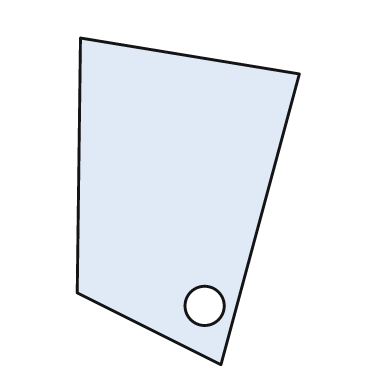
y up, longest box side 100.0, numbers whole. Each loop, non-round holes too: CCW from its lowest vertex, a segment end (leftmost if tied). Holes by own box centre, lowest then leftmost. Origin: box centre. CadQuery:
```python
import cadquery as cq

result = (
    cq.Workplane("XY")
    .moveTo(10.0, -50.0)
    .lineTo(34.0, 39.0)
    .lineTo(-33.0, 50.0)
    .lineTo(-34.0, -28.0)
    .close()
    .moveTo(5.0, -32.0)
    .circle(6.0)
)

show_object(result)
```